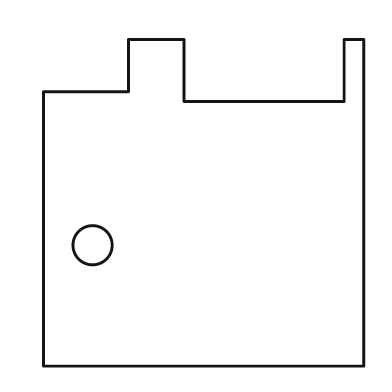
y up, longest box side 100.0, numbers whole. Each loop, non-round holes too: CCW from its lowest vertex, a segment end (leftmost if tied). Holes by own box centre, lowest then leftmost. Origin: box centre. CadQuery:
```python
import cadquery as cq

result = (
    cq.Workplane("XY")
    .moveTo(-49.0, -50.0)
    .lineTo(49.0, -50.0)
    .lineTo(49.0, 50.0)
    .lineTo(43.0, 50.0)
    .lineTo(43.0, 31.0)
    .lineTo(-6.0, 31.0)
    .lineTo(-6.0, 50.0)
    .lineTo(-23.0, 50.0)
    .lineTo(-23.0, 34.0)
    .lineTo(-49.0, 34.0)
    .close()
    .moveTo(-34.0, -13.0)
    .circle(6.0)
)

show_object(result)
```